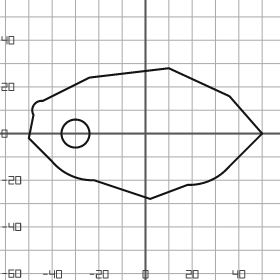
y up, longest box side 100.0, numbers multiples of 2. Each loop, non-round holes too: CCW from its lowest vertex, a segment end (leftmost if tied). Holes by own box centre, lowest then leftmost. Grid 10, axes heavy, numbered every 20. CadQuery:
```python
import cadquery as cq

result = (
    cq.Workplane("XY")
    .moveTo(2.0, -28.0)
    .lineTo(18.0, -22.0)
    .threePointArc((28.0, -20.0), (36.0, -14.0))
    .lineTo(50.0, 0.0)
    .lineTo(36.0, 16.0)
    .lineTo(10.0, 28.0)
    .lineTo(-24.0, 24.0)
    .lineTo(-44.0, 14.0)
    .threePointArc((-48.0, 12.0), (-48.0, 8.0))
    .lineTo(-50.0, -2.0)
    .lineTo(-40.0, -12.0)
    .threePointArc((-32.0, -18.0), (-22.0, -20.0))
    .close()
    .moveTo(-30.0, 0.0)
    .circle(6.0)
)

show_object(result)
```